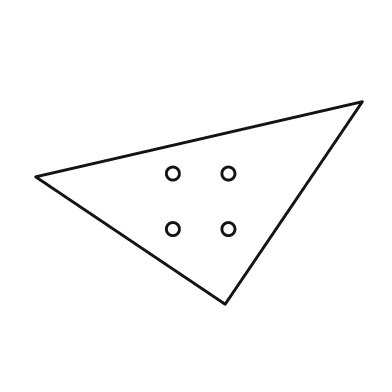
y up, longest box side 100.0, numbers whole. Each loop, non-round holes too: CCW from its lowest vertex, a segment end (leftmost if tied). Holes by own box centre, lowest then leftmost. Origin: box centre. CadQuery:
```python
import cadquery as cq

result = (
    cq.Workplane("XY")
    .moveTo(8.0, -31.0)
    .lineTo(50.0, 31.0)
    .lineTo(-50.0, 8.0)
    .close()
    .moveTo(-8.0, -8.0)
    .circle(2.0)
    .moveTo(9.0, -8.0)
    .circle(2.0)
    .moveTo(-8.0, 9.0)
    .circle(2.0)
    .moveTo(9.0, 9.0)
    .circle(2.0)
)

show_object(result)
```